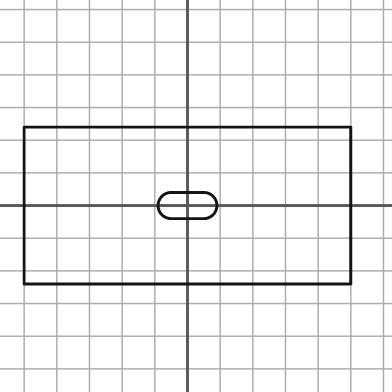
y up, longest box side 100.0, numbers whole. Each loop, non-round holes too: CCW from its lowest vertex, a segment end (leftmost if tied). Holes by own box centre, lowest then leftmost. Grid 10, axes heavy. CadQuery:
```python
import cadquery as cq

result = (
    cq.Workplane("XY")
    .moveTo(-50.0, -24.0)
    .lineTo(50.0, -24.0)
    .lineTo(50.0, 24.0)
    .lineTo(-50.0, 24.0)
    .close()
    .moveTo(-5.0, -4.0)
    .lineTo(5.0, -4.0)
    .threePointArc((9.0, 0.0), (5.0, 4.0))
    .lineTo(-5.0, 4.0)
    .threePointArc((-9.0, 0.0), (-5.0, -4.0))
    .close()
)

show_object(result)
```